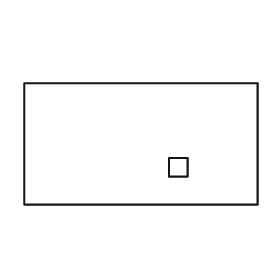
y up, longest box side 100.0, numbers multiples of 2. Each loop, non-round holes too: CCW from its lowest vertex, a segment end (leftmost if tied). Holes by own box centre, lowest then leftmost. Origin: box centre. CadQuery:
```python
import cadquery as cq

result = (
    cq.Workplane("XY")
    .moveTo(-50.0, -26.0)
    .lineTo(50.0, -26.0)
    .lineTo(50.0, 26.0)
    .lineTo(-50.0, 26.0)
    .close()
    .moveTo(12.0, -14.0)
    .lineTo(20.0, -14.0)
    .lineTo(20.0, -6.0)
    .lineTo(12.0, -6.0)
    .close()
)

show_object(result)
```